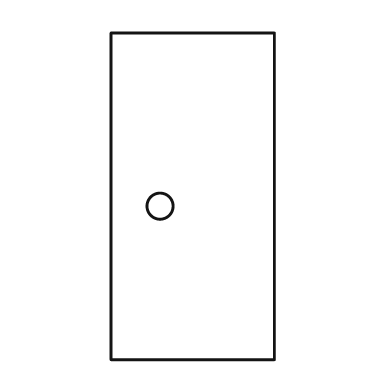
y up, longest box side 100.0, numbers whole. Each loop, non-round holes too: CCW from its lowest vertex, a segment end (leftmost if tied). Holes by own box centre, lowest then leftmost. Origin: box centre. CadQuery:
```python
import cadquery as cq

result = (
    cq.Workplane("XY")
    .moveTo(-25.0, -50.0)
    .lineTo(25.0, -50.0)
    .lineTo(25.0, 50.0)
    .lineTo(-25.0, 50.0)
    .close()
    .moveTo(-10.0, -3.0)
    .circle(4.0)
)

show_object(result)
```